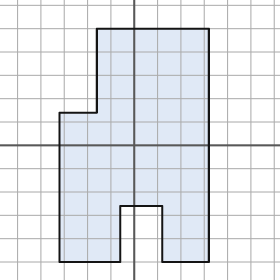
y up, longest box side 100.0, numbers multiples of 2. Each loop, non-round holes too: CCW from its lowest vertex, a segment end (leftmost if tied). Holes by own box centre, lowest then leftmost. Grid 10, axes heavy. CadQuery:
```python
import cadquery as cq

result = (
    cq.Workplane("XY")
    .moveTo(-32.0, -50.0)
    .lineTo(-6.0, -50.0)
    .lineTo(-6.0, -26.0)
    .lineTo(12.0, -26.0)
    .lineTo(12.0, -50.0)
    .lineTo(32.0, -50.0)
    .lineTo(32.0, 50.0)
    .lineTo(-16.0, 50.0)
    .lineTo(-16.0, 14.0)
    .lineTo(-32.0, 14.0)
    .close()
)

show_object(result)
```